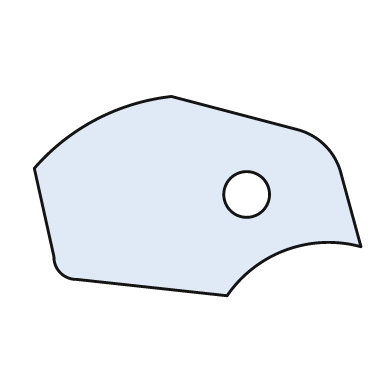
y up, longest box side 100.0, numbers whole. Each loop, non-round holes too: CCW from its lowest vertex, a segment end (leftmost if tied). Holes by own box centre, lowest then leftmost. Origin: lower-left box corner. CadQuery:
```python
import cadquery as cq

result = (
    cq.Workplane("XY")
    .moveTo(59.0, 0.0)
    .threePointArc((77.0, 14.0), (100.0, 15.0))
    .lineTo(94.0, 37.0)
    .threePointArc((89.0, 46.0), (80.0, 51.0))
    .lineTo(42.0, 61.0)
    .threePointArc((19.0, 54.0), (0.0, 39.0))
    .lineTo(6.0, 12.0)
    .threePointArc((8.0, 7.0), (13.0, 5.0))
    .close()
    .moveTo(65.0, 31.0)
    .circle(7.0)
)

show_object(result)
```